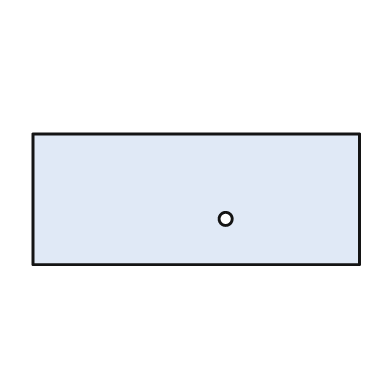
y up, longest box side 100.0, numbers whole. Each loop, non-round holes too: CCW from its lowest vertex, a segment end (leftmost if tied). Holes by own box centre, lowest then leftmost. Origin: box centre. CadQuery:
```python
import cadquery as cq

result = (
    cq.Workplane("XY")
    .moveTo(-50.0, -20.0)
    .lineTo(50.0, -20.0)
    .lineTo(50.0, 20.0)
    .lineTo(-50.0, 20.0)
    .close()
    .moveTo(9.0, -6.0)
    .circle(2.0)
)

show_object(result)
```